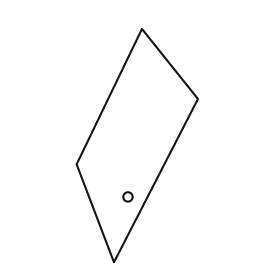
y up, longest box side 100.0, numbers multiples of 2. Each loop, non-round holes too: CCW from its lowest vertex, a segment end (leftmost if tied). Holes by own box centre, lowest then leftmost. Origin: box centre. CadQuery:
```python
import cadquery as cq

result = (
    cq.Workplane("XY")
    .moveTo(-10.0, -50.0)
    .lineTo(26.0, 20.0)
    .lineTo(2.0, 50.0)
    .lineTo(-26.0, -8.0)
    .close()
    .moveTo(-4.0, -22.0)
    .circle(2.0)
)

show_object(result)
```